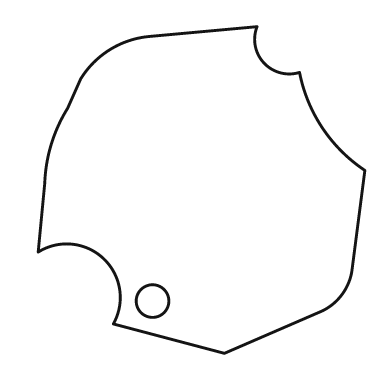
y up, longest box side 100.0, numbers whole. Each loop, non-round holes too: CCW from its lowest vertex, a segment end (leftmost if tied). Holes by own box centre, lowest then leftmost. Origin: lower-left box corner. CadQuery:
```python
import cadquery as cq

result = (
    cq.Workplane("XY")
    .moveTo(57.0, 0.0)
    .lineTo(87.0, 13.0)
    .threePointArc((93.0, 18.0), (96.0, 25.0))
    .lineTo(100.0, 56.0)
    .threePointArc((87.0, 69.0), (80.0, 86.0))
    .threePointArc((69.0, 89.0), (67.0, 100.0))
    .lineTo(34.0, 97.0)
    .threePointArc((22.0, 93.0), (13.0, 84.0))
    .lineTo(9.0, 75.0)
    .threePointArc((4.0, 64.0), (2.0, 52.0))
    .lineTo(0.0, 31.0)
    .threePointArc((20.0, 29.0), (23.0, 9.0))
    .close()
    .moveTo(35.0, 16.0)
    .circle(5.0)
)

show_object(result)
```